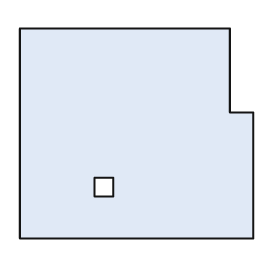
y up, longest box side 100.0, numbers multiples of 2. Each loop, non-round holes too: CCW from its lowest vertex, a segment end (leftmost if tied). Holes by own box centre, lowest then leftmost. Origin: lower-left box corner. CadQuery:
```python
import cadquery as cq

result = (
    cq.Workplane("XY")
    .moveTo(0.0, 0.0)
    .lineTo(100.0, 0.0)
    .lineTo(100.0, 54.0)
    .lineTo(90.0, 54.0)
    .lineTo(90.0, 90.0)
    .lineTo(0.0, 90.0)
    .close()
    .moveTo(32.0, 18.0)
    .lineTo(40.0, 18.0)
    .lineTo(40.0, 26.0)
    .lineTo(32.0, 26.0)
    .close()
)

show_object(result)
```